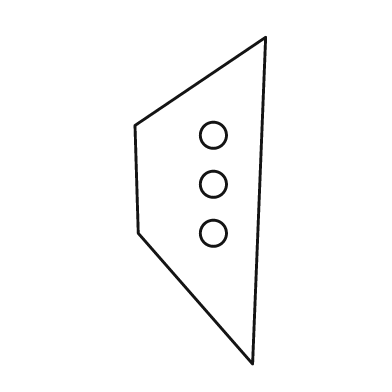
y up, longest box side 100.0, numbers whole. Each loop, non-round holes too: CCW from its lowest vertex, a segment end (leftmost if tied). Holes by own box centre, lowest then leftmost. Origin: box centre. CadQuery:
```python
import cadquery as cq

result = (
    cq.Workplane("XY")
    .moveTo(16.0, -50.0)
    .lineTo(20.0, 50.0)
    .lineTo(-20.0, 23.0)
    .lineTo(-19.0, -10.0)
    .close()
    .moveTo(4.0, -10.0)
    .circle(4.0)
    .moveTo(4.0, 5.0)
    .circle(4.0)
    .moveTo(4.0, 20.0)
    .circle(4.0)
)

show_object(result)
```